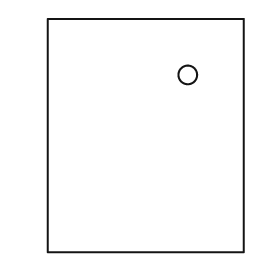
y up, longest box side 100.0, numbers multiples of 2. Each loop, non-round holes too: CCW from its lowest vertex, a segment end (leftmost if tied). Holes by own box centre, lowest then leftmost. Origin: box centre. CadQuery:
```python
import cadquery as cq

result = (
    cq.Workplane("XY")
    .moveTo(-42.0, -50.0)
    .lineTo(42.0, -50.0)
    .lineTo(42.0, 50.0)
    .lineTo(-42.0, 50.0)
    .close()
    .moveTo(18.0, 26.0)
    .circle(4.0)
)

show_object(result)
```